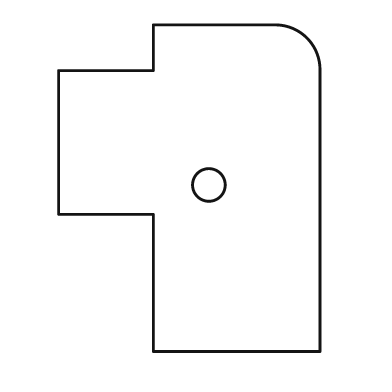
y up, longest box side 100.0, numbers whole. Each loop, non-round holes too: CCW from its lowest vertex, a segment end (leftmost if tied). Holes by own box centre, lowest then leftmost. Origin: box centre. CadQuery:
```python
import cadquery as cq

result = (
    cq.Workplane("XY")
    .moveTo(-11.0, -50.0)
    .lineTo(40.0, -50.0)
    .lineTo(40.0, 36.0)
    .threePointArc((36.0, 46.0), (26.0, 50.0))
    .lineTo(-11.0, 50.0)
    .lineTo(-11.0, 36.0)
    .lineTo(-40.0, 36.0)
    .lineTo(-40.0, -8.0)
    .lineTo(-11.0, -8.0)
    .close()
    .moveTo(6.0, 1.0)
    .circle(5.0)
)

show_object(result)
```